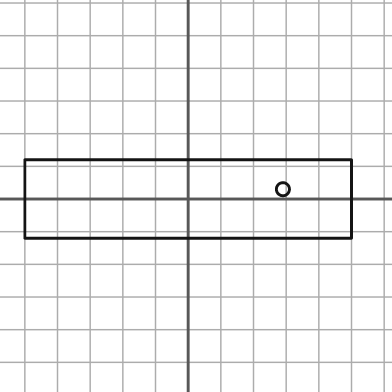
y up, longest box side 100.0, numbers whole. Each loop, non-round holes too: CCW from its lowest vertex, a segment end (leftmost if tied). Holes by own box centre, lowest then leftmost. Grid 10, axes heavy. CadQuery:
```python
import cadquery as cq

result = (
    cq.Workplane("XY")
    .moveTo(-50.0, -12.0)
    .lineTo(50.0, -12.0)
    .lineTo(50.0, 12.0)
    .lineTo(-50.0, 12.0)
    .close()
    .moveTo(29.0, 3.0)
    .circle(2.0)
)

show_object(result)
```